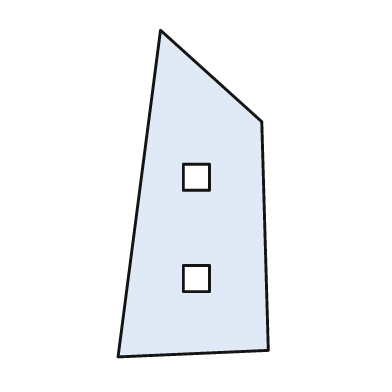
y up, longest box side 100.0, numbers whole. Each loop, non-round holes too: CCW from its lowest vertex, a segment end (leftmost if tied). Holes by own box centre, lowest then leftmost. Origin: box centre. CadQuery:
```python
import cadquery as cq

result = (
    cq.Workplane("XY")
    .moveTo(-23.0, -50.0)
    .lineTo(23.0, -48.0)
    .lineTo(21.0, 22.0)
    .lineTo(-10.0, 50.0)
    .close()
    .moveTo(-3.0, -30.0)
    .lineTo(5.0, -30.0)
    .lineTo(5.0, -22.0)
    .lineTo(-3.0, -22.0)
    .close()
    .moveTo(-3.0, 1.0)
    .lineTo(5.0, 1.0)
    .lineTo(5.0, 9.0)
    .lineTo(-3.0, 9.0)
    .close()
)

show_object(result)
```